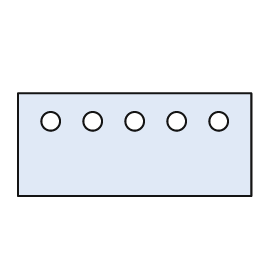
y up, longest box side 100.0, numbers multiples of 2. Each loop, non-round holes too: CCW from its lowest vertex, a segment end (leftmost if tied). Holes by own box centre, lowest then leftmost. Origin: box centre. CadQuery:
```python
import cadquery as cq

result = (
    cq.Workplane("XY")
    .moveTo(-50.0, -22.0)
    .lineTo(50.0, -22.0)
    .lineTo(50.0, 22.0)
    .lineTo(-50.0, 22.0)
    .close()
    .moveTo(-36.0, 10.0)
    .circle(4.0)
    .moveTo(-18.0, 10.0)
    .circle(4.0)
    .moveTo(0.0, 10.0)
    .circle(4.0)
    .moveTo(18.0, 10.0)
    .circle(4.0)
    .moveTo(36.0, 10.0)
    .circle(4.0)
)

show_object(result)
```